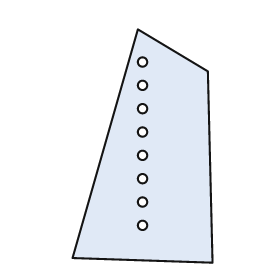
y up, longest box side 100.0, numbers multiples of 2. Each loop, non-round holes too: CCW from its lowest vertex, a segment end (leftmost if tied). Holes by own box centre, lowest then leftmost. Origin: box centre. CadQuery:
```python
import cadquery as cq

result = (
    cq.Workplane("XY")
    .moveTo(30.0, -50.0)
    .lineTo(28.0, 32.0)
    .lineTo(-2.0, 50.0)
    .lineTo(-30.0, -48.0)
    .close()
    .moveTo(0.0, -34.0)
    .circle(2.0)
    .moveTo(0.0, -24.0)
    .circle(2.0)
    .moveTo(0.0, -14.0)
    .circle(2.0)
    .moveTo(0.0, -4.0)
    .circle(2.0)
    .moveTo(0.0, 6.0)
    .circle(2.0)
    .moveTo(0.0, 16.0)
    .circle(2.0)
    .moveTo(0.0, 26.0)
    .circle(2.0)
    .moveTo(0.0, 36.0)
    .circle(2.0)
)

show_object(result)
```